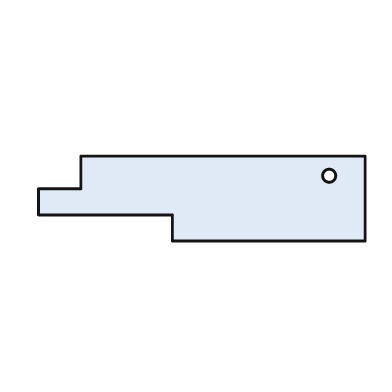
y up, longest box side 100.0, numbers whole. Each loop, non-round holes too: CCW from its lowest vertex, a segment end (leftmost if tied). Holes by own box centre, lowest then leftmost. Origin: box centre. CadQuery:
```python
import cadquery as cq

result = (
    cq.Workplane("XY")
    .moveTo(-9.0, -13.0)
    .lineTo(50.0, -13.0)
    .lineTo(50.0, 13.0)
    .lineTo(-37.0, 13.0)
    .lineTo(-37.0, 3.0)
    .lineTo(-50.0, 3.0)
    .lineTo(-50.0, -5.0)
    .lineTo(-9.0, -5.0)
    .close()
    .moveTo(39.0, 7.0)
    .circle(2.0)
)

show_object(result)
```